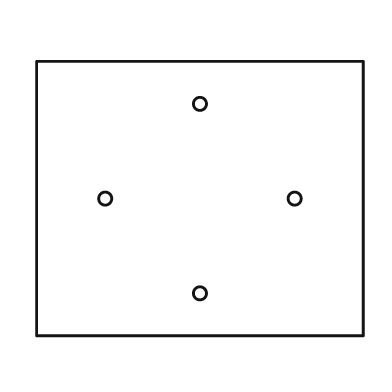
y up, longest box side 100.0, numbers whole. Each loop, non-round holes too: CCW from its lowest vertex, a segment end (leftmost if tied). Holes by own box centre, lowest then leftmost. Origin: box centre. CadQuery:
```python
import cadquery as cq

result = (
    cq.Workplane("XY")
    .moveTo(-50.0, -42.0)
    .lineTo(50.0, -42.0)
    .lineTo(50.0, 42.0)
    .lineTo(-50.0, 42.0)
    .close()
    .moveTo(0.0, -29.0)
    .circle(2.0)
    .moveTo(-29.0, 0.0)
    .circle(2.0)
    .moveTo(29.0, 0.0)
    .circle(2.0)
    .moveTo(0.0, 29.0)
    .circle(2.0)
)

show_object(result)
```